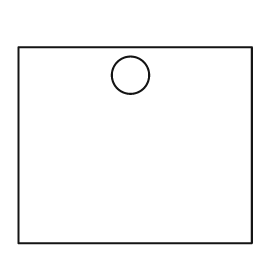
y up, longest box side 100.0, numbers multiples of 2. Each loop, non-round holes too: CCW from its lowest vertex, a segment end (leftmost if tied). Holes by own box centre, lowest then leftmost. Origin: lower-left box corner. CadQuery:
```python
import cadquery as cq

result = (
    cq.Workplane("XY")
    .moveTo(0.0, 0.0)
    .lineTo(100.0, 0.0)
    .lineTo(100.0, 84.0)
    .lineTo(0.0, 84.0)
    .close()
    .moveTo(48.0, 72.0)
    .circle(8.0)
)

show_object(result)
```